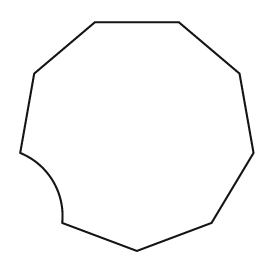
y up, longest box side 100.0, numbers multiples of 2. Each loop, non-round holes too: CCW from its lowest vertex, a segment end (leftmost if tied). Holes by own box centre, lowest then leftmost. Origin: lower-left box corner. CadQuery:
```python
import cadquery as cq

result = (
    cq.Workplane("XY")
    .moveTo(50.0, 0.0)
    .lineTo(82.0, 12.0)
    .lineTo(100.0, 42.0)
    .lineTo(94.0, 76.0)
    .lineTo(68.0, 98.0)
    .lineTo(32.0, 98.0)
    .lineTo(6.0, 76.0)
    .lineTo(0.0, 42.0)
    .threePointArc((14.0, 30.0), (18.0, 12.0))
    .close()
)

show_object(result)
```